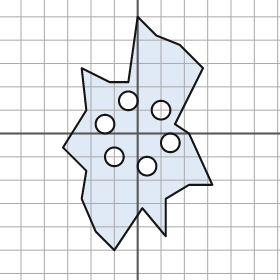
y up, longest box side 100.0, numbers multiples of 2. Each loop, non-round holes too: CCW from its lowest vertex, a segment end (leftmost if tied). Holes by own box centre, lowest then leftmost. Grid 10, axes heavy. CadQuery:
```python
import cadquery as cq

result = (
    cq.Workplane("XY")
    .moveTo(-10.0, -50.0)
    .lineTo(2.0, -32.0)
    .lineTo(12.0, -44.0)
    .lineTo(12.0, -28.0)
    .lineTo(22.0, -22.0)
    .lineTo(32.0, -22.0)
    .lineTo(22.0, 0.0)
    .lineTo(16.0, 4.0)
    .lineTo(28.0, 28.0)
    .lineTo(18.0, 38.0)
    .lineTo(8.0, 42.0)
    .lineTo(0.0, 50.0)
    .lineTo(-4.0, 22.0)
    .lineTo(-12.0, 22.0)
    .lineTo(-24.0, 28.0)
    .lineTo(-22.0, 10.0)
    .lineTo(-32.0, -6.0)
    .lineTo(-22.0, -16.0)
    .lineTo(-24.0, -28.0)
    .lineTo(-18.0, -42.0)
    .close()
    .moveTo(4.0, -14.0)
    .circle(4.0)
    .moveTo(-10.0, -10.0)
    .circle(4.0)
    .moveTo(14.0, -4.0)
    .circle(4.0)
    .moveTo(-14.0, 4.0)
    .circle(4.0)
    .moveTo(10.0, 10.0)
    .circle(4.0)
    .moveTo(-4.0, 14.0)
    .circle(4.0)
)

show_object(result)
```